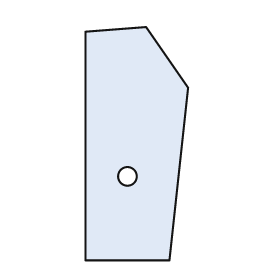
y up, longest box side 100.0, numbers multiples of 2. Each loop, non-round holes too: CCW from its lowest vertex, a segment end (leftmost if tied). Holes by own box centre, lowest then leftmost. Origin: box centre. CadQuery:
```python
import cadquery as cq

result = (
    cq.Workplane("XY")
    .moveTo(-22.0, -50.0)
    .lineTo(14.0, -50.0)
    .lineTo(22.0, 24.0)
    .lineTo(4.0, 50.0)
    .lineTo(-22.0, 48.0)
    .close()
    .moveTo(-4.0, -14.0)
    .circle(4.0)
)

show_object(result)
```